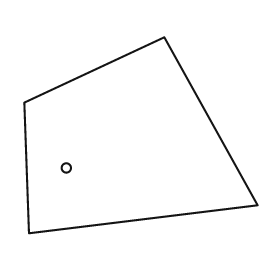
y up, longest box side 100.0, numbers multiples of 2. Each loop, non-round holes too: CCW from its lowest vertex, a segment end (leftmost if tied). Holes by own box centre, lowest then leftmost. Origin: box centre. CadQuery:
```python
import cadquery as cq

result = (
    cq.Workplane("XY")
    .moveTo(-48.0, -42.0)
    .lineTo(50.0, -30.0)
    .lineTo(10.0, 42.0)
    .lineTo(-50.0, 14.0)
    .close()
    .moveTo(-32.0, -14.0)
    .circle(2.0)
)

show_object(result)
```